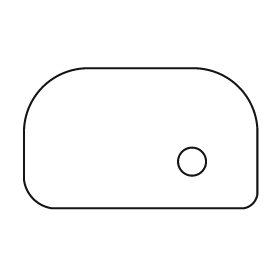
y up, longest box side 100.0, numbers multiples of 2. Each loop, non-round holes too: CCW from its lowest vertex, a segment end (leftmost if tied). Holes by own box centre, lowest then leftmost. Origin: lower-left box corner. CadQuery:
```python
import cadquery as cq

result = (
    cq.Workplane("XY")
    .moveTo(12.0, 0.0)
    .lineTo(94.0, 0.0)
    .threePointArc((98.0, 2.0), (100.0, 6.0))
    .lineTo(100.0, 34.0)
    .threePointArc((92.0, 52.0), (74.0, 60.0))
    .lineTo(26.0, 60.0)
    .threePointArc((8.0, 52.0), (0.0, 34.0))
    .lineTo(0.0, 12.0)
    .threePointArc((4.0, 4.0), (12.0, 0.0))
    .close()
    .moveTo(72.0, 20.0)
    .circle(6.0)
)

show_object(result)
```